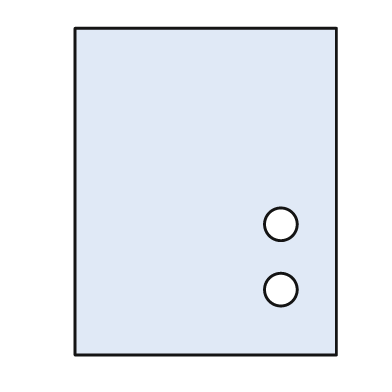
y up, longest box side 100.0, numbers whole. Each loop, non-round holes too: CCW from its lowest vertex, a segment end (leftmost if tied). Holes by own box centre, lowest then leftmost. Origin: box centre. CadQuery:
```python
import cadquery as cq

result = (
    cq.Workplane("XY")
    .moveTo(-40.0, -50.0)
    .lineTo(40.0, -50.0)
    .lineTo(40.0, 50.0)
    .lineTo(-40.0, 50.0)
    .close()
    .moveTo(23.0, -30.0)
    .circle(5.0)
    .moveTo(23.0, -10.0)
    .circle(5.0)
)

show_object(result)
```